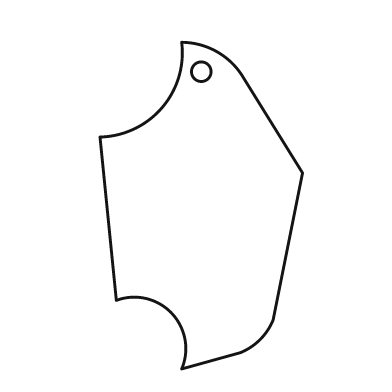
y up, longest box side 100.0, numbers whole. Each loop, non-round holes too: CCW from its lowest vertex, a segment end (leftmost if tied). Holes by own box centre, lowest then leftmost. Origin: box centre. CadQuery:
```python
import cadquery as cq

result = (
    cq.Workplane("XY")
    .moveTo(-6.0, -50.0)
    .lineTo(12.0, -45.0)
    .threePointArc((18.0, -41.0), (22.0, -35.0))
    .lineTo(31.0, 10.0)
    .lineTo(13.0, 39.0)
    .threePointArc((5.0, 47.0), (-6.0, 50.0))
    .threePointArc((-12.0, 30.0), (-31.0, 21.0))
    .lineTo(-26.0, -29.0)
    .threePointArc((-9.0, -33.0), (-6.0, -50.0))
    .close()
    .moveTo(0.0, 41.0)
    .circle(3.0)
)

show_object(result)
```